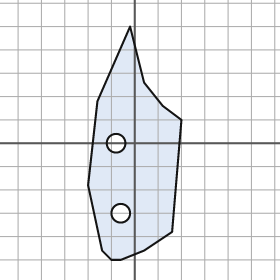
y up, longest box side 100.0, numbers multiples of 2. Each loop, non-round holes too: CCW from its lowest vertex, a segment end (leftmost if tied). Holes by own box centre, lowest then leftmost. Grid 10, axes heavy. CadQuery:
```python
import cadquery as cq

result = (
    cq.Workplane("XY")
    .moveTo(-10.0, -50.0)
    .lineTo(-6.0, -50.0)
    .lineTo(4.0, -46.0)
    .lineTo(16.0, -38.0)
    .lineTo(20.0, 10.0)
    .lineTo(12.0, 16.0)
    .lineTo(4.0, 26.0)
    .lineTo(-2.0, 50.0)
    .lineTo(-16.0, 18.0)
    .lineTo(-20.0, -18.0)
    .lineTo(-14.0, -46.0)
    .close()
    .moveTo(-6.0, -30.0)
    .circle(4.0)
    .moveTo(-8.0, 0.0)
    .circle(4.0)
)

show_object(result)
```